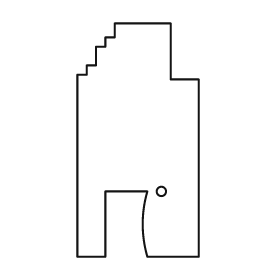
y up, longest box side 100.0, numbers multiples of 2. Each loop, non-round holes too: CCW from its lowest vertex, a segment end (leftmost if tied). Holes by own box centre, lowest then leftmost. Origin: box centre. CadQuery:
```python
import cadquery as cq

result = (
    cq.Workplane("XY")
    .moveTo(-26.0, -50.0)
    .lineTo(-14.0, -50.0)
    .lineTo(-14.0, -22.0)
    .lineTo(4.0, -22.0)
    .threePointArc((2.0, -36.0), (4.0, -50.0))
    .lineTo(26.0, -50.0)
    .lineTo(26.0, 26.0)
    .lineTo(14.0, 26.0)
    .lineTo(14.0, 50.0)
    .lineTo(-10.0, 50.0)
    .lineTo(-10.0, 44.0)
    .lineTo(-14.0, 44.0)
    .lineTo(-14.0, 40.0)
    .lineTo(-18.0, 40.0)
    .lineTo(-18.0, 32.0)
    .lineTo(-22.0, 32.0)
    .lineTo(-22.0, 28.0)
    .lineTo(-26.0, 28.0)
    .close()
    .moveTo(10.0, -22.0)
    .circle(2.0)
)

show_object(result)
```